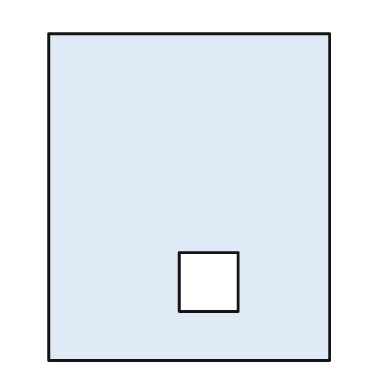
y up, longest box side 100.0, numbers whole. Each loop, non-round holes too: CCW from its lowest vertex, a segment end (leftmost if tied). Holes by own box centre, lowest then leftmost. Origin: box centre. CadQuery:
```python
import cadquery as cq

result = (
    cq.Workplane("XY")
    .moveTo(-43.0, -50.0)
    .lineTo(43.0, -50.0)
    .lineTo(43.0, 50.0)
    .lineTo(-43.0, 50.0)
    .close()
    .moveTo(-3.0, -35.0)
    .lineTo(15.0, -35.0)
    .lineTo(15.0, -17.0)
    .lineTo(-3.0, -17.0)
    .close()
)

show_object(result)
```